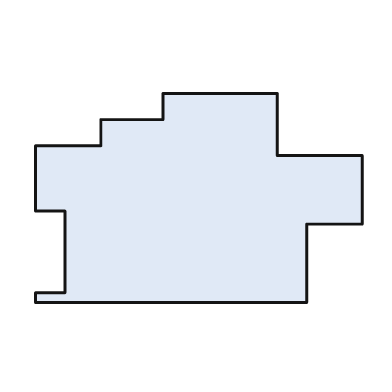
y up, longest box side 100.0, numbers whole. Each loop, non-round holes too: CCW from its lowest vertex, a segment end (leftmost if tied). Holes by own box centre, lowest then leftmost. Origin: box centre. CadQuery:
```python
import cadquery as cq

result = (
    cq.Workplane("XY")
    .moveTo(-50.0, -32.0)
    .lineTo(33.0, -32.0)
    .lineTo(33.0, -8.0)
    .lineTo(50.0, -8.0)
    .lineTo(50.0, 13.0)
    .lineTo(24.0, 13.0)
    .lineTo(24.0, 32.0)
    .lineTo(-11.0, 32.0)
    .lineTo(-11.0, 24.0)
    .lineTo(-30.0, 24.0)
    .lineTo(-30.0, 16.0)
    .lineTo(-50.0, 16.0)
    .lineTo(-50.0, -4.0)
    .lineTo(-41.0, -4.0)
    .lineTo(-41.0, -29.0)
    .lineTo(-50.0, -29.0)
    .close()
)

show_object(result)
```